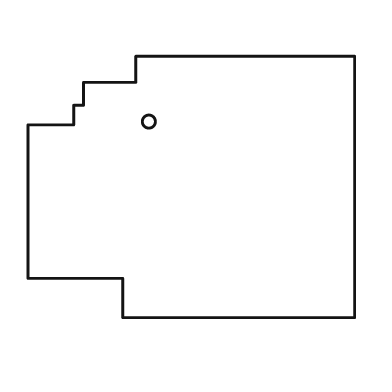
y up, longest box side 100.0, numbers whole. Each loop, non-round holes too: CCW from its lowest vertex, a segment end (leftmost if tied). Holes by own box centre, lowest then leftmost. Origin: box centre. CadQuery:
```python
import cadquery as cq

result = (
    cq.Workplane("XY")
    .moveTo(-21.0, -40.0)
    .lineTo(50.0, -40.0)
    .lineTo(50.0, 40.0)
    .lineTo(-17.0, 40.0)
    .lineTo(-17.0, 32.0)
    .lineTo(-33.0, 32.0)
    .lineTo(-33.0, 25.0)
    .lineTo(-36.0, 25.0)
    .lineTo(-36.0, 19.0)
    .lineTo(-50.0, 19.0)
    .lineTo(-50.0, -28.0)
    .lineTo(-21.0, -28.0)
    .close()
    .moveTo(-13.0, 20.0)
    .circle(2.0)
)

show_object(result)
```